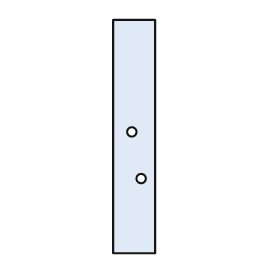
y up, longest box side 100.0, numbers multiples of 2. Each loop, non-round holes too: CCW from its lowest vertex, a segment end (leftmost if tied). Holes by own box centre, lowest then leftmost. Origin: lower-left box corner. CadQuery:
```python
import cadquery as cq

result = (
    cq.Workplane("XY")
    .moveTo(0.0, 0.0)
    .lineTo(18.0, 0.0)
    .lineTo(18.0, 100.0)
    .lineTo(0.0, 100.0)
    .close()
    .moveTo(12.0, 32.0)
    .circle(2.0)
    .moveTo(8.0, 52.0)
    .circle(2.0)
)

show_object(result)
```